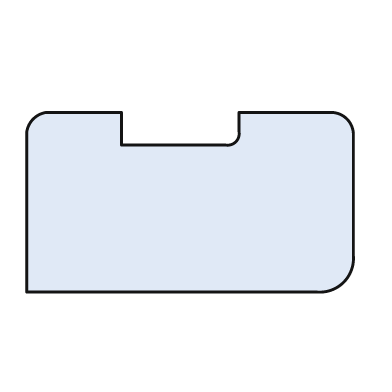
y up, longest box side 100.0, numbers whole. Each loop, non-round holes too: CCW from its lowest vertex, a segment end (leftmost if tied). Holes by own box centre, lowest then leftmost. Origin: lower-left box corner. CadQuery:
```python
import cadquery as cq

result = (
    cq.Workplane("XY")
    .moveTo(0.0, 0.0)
    .lineTo(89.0, 0.0)
    .threePointArc((97.0, 3.0), (100.0, 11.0))
    .lineTo(100.0, 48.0)
    .threePointArc((98.0, 53.0), (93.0, 55.0))
    .lineTo(65.0, 55.0)
    .lineTo(65.0, 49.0)
    .threePointArc((64.0, 46.0), (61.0, 45.0))
    .lineTo(29.0, 45.0)
    .lineTo(29.0, 55.0)
    .lineTo(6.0, 55.0)
    .threePointArc((2.0, 53.0), (0.0, 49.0))
    .close()
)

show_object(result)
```